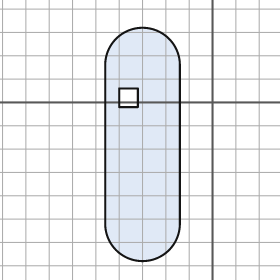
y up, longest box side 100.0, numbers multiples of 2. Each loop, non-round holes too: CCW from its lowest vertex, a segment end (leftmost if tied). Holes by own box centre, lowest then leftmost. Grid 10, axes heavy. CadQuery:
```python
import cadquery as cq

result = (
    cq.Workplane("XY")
    .moveTo(-46.0, -52.0)
    .threePointArc((-30.0, -68.0), (-14.0, -52.0))
    .lineTo(-14.0, 16.0)
    .threePointArc((-30.0, 32.0), (-46.0, 16.0))
    .close()
    .moveTo(-40.0, -2.0)
    .lineTo(-32.0, -2.0)
    .lineTo(-32.0, 6.0)
    .lineTo(-40.0, 6.0)
    .close()
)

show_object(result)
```